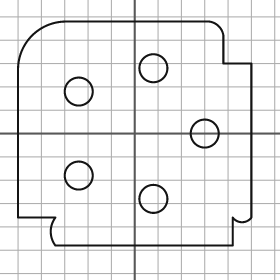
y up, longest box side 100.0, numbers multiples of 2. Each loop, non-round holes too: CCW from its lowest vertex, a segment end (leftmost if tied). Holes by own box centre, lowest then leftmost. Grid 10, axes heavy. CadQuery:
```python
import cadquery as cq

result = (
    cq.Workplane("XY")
    .moveTo(-34.0, -48.0)
    .lineTo(42.0, -48.0)
    .lineTo(42.0, -36.0)
    .threePointArc((46.0, -38.0), (50.0, -36.0))
    .lineTo(50.0, 30.0)
    .lineTo(38.0, 30.0)
    .lineTo(38.0, 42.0)
    .threePointArc((36.0, 46.0), (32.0, 48.0))
    .lineTo(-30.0, 48.0)
    .threePointArc((-44.0, 42.0), (-50.0, 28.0))
    .lineTo(-50.0, -36.0)
    .lineTo(-34.0, -36.0)
    .threePointArc((-36.0, -42.0), (-34.0, -48.0))
    .close()
    .moveTo(8.0, -28.0)
    .circle(6.0)
    .moveTo(-24.0, -18.0)
    .circle(6.0)
    .moveTo(30.0, 0.0)
    .circle(6.0)
    .moveTo(-24.0, 18.0)
    .circle(6.0)
    .moveTo(8.0, 28.0)
    .circle(6.0)
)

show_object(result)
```